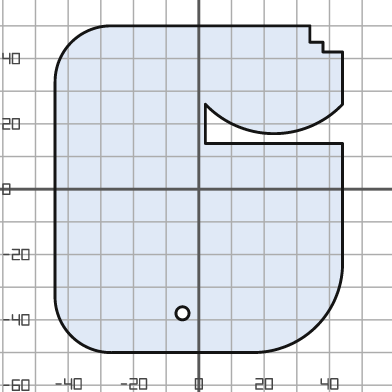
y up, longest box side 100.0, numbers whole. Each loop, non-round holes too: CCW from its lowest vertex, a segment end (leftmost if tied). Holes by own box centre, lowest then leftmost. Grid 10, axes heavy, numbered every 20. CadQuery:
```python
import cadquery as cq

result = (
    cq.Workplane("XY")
    .moveTo(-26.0, -50.0)
    .lineTo(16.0, -50.0)
    .threePointArc((36.0, -42.0), (44.0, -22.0))
    .lineTo(44.0, 14.0)
    .lineTo(2.0, 14.0)
    .lineTo(2.0, 26.0)
    .threePointArc((23.0, 17.0), (44.0, 26.0))
    .lineTo(44.0, 42.0)
    .lineTo(38.0, 42.0)
    .lineTo(38.0, 45.0)
    .lineTo(34.0, 45.0)
    .lineTo(34.0, 50.0)
    .lineTo(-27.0, 50.0)
    .threePointArc((-39.0, 45.0), (-44.0, 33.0))
    .lineTo(-44.0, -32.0)
    .threePointArc((-39.0, -45.0), (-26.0, -50.0))
    .close()
    .moveTo(-5.0, -38.0)
    .circle(2.0)
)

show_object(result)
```